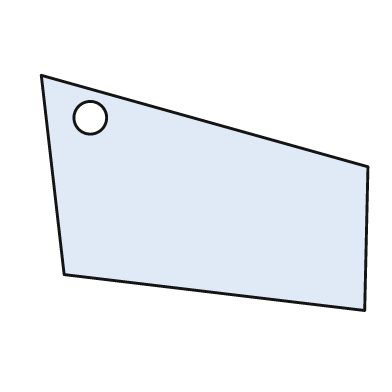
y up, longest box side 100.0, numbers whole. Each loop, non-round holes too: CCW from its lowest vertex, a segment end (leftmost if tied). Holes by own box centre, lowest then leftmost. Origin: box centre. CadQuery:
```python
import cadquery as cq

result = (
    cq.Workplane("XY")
    .moveTo(49.0, -36.0)
    .lineTo(50.0, 8.0)
    .lineTo(-50.0, 36.0)
    .lineTo(-43.0, -25.0)
    .close()
    .moveTo(-35.0, 23.0)
    .circle(5.0)
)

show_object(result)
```